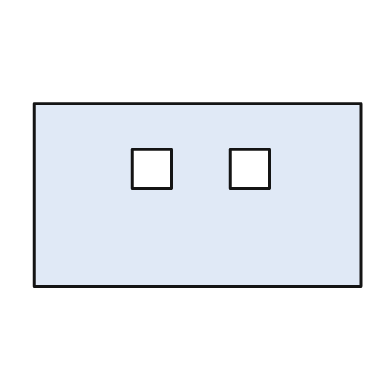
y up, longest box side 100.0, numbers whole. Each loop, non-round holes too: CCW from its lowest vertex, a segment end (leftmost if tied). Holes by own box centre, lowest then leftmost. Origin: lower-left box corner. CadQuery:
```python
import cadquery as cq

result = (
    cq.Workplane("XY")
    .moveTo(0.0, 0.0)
    .lineTo(100.0, 0.0)
    .lineTo(100.0, 56.0)
    .lineTo(0.0, 56.0)
    .close()
    .moveTo(30.0, 30.0)
    .lineTo(42.0, 30.0)
    .lineTo(42.0, 42.0)
    .lineTo(30.0, 42.0)
    .close()
    .moveTo(60.0, 30.0)
    .lineTo(72.0, 30.0)
    .lineTo(72.0, 42.0)
    .lineTo(60.0, 42.0)
    .close()
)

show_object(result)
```